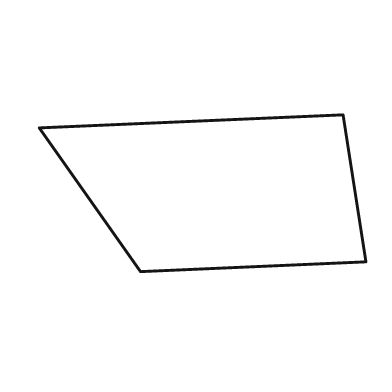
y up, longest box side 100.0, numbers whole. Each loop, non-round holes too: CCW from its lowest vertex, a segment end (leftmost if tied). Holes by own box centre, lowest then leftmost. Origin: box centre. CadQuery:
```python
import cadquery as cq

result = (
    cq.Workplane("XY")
    .moveTo(-19.0, -24.0)
    .lineTo(50.0, -21.0)
    .lineTo(43.0, 24.0)
    .lineTo(-50.0, 20.0)
    .close()
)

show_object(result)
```